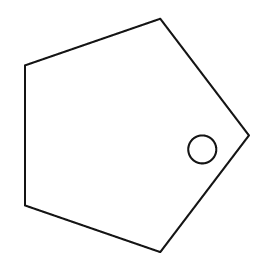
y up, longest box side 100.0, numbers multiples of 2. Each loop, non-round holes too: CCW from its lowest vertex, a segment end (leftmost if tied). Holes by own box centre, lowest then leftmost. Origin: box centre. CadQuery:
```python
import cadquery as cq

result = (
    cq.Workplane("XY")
    .moveTo(10.0, -50.0)
    .lineTo(48.0, 0.0)
    .lineTo(10.0, 50.0)
    .lineTo(-48.0, 30.0)
    .lineTo(-48.0, -30.0)
    .close()
    .moveTo(28.0, -6.0)
    .circle(6.0)
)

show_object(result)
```